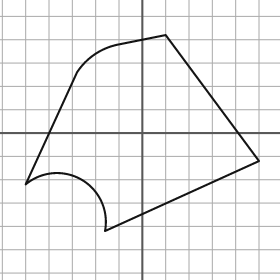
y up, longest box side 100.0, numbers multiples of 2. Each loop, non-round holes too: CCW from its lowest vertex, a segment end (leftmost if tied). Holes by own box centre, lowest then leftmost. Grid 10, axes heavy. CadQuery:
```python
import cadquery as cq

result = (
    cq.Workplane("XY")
    .moveTo(-16.0, -42.0)
    .lineTo(50.0, -12.0)
    .lineTo(10.0, 42.0)
    .lineTo(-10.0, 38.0)
    .threePointArc((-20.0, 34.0), (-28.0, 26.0))
    .lineTo(-50.0, -22.0)
    .threePointArc((-26.0, -20.0), (-16.0, -42.0))
    .close()
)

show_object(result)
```